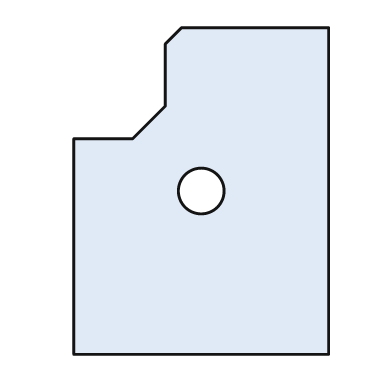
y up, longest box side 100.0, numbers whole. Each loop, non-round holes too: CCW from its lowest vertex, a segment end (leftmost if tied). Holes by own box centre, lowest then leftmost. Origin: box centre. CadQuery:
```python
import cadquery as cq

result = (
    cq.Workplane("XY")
    .moveTo(-39.0, -50.0)
    .lineTo(39.0, -50.0)
    .lineTo(39.0, 50.0)
    .lineTo(-6.0, 50.0)
    .lineTo(-11.0, 45.0)
    .lineTo(-11.0, 26.0)
    .lineTo(-21.0, 16.0)
    .lineTo(-39.0, 16.0)
    .close()
    .moveTo(0.0, 0.0)
    .circle(7.0)
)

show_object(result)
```